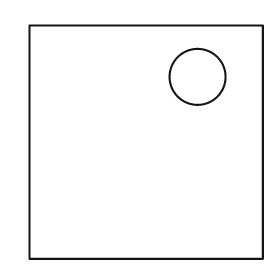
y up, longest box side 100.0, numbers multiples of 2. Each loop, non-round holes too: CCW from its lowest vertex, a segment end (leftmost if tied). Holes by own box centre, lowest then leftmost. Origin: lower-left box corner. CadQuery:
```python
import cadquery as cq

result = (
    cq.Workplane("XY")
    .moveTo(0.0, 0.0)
    .lineTo(100.0, 0.0)
    .lineTo(100.0, 100.0)
    .lineTo(0.0, 100.0)
    .close()
    .moveTo(72.0, 78.0)
    .circle(12.0)
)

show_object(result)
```